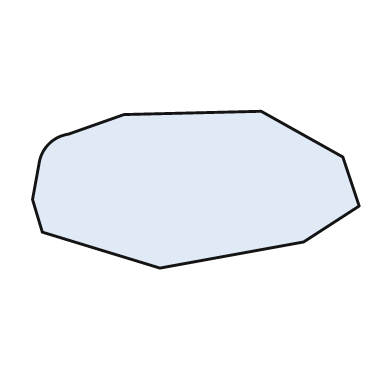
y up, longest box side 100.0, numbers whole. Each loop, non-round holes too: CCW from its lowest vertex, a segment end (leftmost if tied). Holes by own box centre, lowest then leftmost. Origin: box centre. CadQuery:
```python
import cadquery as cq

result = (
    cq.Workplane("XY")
    .moveTo(-11.0, -24.0)
    .lineTo(33.0, -16.0)
    .lineTo(50.0, -5.0)
    .lineTo(45.0, 10.0)
    .lineTo(20.0, 24.0)
    .lineTo(-22.0, 23.0)
    .lineTo(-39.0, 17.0)
    .threePointArc((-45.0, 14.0), (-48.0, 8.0))
    .lineTo(-50.0, -3.0)
    .lineTo(-47.0, -13.0)
    .close()
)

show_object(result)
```